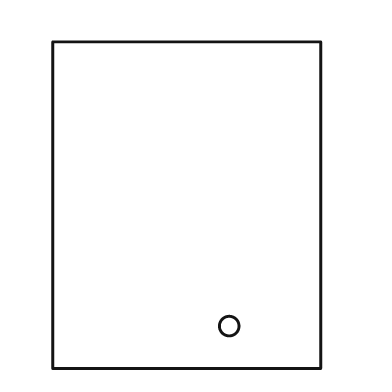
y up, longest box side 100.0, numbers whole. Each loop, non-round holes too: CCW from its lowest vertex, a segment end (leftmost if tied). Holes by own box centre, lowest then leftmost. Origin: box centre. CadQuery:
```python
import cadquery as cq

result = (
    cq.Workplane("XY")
    .moveTo(-41.0, -50.0)
    .lineTo(41.0, -50.0)
    .lineTo(41.0, 50.0)
    .lineTo(-41.0, 50.0)
    .close()
    .moveTo(13.0, -37.0)
    .circle(3.0)
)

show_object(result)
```